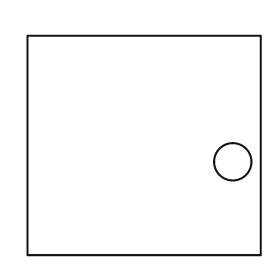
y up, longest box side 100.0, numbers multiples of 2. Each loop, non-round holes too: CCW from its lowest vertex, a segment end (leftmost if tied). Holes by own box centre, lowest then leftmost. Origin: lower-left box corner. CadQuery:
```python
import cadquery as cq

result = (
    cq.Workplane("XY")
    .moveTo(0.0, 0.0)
    .lineTo(100.0, 0.0)
    .lineTo(100.0, 94.0)
    .lineTo(0.0, 94.0)
    .close()
    .moveTo(88.0, 40.0)
    .circle(8.0)
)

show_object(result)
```